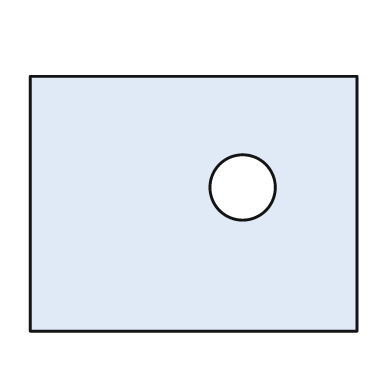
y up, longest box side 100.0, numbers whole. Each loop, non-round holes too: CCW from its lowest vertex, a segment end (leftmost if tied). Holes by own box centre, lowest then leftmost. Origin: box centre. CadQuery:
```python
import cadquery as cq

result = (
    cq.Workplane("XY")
    .moveTo(-50.0, -39.0)
    .lineTo(50.0, -39.0)
    .lineTo(50.0, 39.0)
    .lineTo(-50.0, 39.0)
    .close()
    .moveTo(15.0, 5.0)
    .circle(10.0)
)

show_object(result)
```